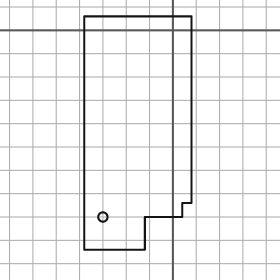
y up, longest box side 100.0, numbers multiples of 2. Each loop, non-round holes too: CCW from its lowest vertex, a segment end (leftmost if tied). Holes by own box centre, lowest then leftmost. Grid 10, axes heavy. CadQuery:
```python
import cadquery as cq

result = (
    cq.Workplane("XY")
    .moveTo(-38.0, -94.0)
    .lineTo(-12.0, -94.0)
    .lineTo(-12.0, -80.0)
    .lineTo(4.0, -80.0)
    .lineTo(4.0, -74.0)
    .lineTo(8.0, -74.0)
    .lineTo(8.0, 6.0)
    .lineTo(-38.0, 6.0)
    .close()
    .moveTo(-30.0, -80.0)
    .circle(2.0)
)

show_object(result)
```